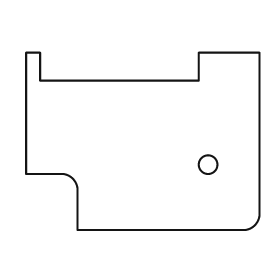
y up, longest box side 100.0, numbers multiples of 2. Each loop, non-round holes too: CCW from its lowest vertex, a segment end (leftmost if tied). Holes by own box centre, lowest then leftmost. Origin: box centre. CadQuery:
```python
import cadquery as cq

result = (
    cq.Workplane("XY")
    .moveTo(-28.0, -38.0)
    .lineTo(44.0, -38.0)
    .threePointArc((48.0, -36.0), (50.0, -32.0))
    .lineTo(50.0, 38.0)
    .lineTo(24.0, 38.0)
    .lineTo(24.0, 26.0)
    .lineTo(-44.0, 26.0)
    .lineTo(-44.0, 38.0)
    .lineTo(-50.0, 38.0)
    .lineTo(-50.0, -14.0)
    .lineTo(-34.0, -14.0)
    .threePointArc((-30.0, -16.0), (-28.0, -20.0))
    .close()
    .moveTo(28.0, -10.0)
    .circle(4.0)
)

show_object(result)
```